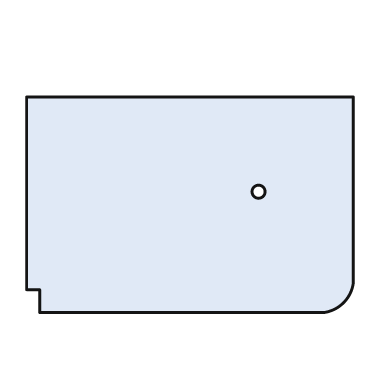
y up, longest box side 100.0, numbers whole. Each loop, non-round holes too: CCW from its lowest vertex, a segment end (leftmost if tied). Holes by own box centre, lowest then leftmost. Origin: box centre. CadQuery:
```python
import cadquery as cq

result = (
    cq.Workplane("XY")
    .moveTo(-46.0, -33.0)
    .lineTo(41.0, -33.0)
    .threePointArc((47.0, -30.0), (50.0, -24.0))
    .lineTo(50.0, 33.0)
    .lineTo(-50.0, 33.0)
    .lineTo(-50.0, -26.0)
    .lineTo(-46.0, -26.0)
    .close()
    .moveTo(21.0, 4.0)
    .circle(2.0)
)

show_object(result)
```